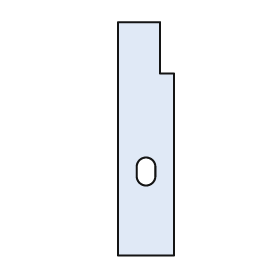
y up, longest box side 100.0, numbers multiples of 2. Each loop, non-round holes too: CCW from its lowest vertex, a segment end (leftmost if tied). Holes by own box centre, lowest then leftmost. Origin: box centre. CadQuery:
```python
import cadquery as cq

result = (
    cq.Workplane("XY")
    .moveTo(-12.0, -50.0)
    .lineTo(12.0, -50.0)
    .lineTo(12.0, 28.0)
    .lineTo(6.0, 28.0)
    .lineTo(6.0, 50.0)
    .lineTo(-12.0, 50.0)
    .close()
    .moveTo(-4.0, -16.0)
    .threePointArc((0.0, -20.0), (4.0, -16.0))
    .lineTo(4.0, -12.0)
    .threePointArc((0.0, -8.0), (-4.0, -12.0))
    .close()
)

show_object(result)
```